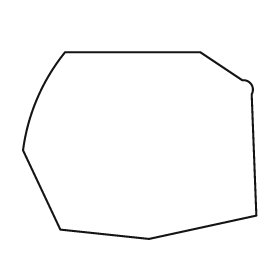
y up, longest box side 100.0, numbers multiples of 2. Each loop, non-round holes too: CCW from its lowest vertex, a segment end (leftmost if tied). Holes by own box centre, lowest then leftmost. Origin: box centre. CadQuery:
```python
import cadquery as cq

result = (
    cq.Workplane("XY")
    .moveTo(4.0, -40.0)
    .lineTo(50.0, -30.0)
    .lineTo(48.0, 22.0)
    .threePointArc((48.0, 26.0), (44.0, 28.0))
    .lineTo(26.0, 40.0)
    .lineTo(-32.0, 40.0)
    .threePointArc((-44.0, 20.0), (-50.0, -2.0))
    .lineTo(-34.0, -36.0)
    .close()
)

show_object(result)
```